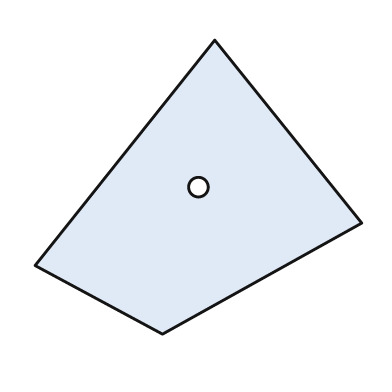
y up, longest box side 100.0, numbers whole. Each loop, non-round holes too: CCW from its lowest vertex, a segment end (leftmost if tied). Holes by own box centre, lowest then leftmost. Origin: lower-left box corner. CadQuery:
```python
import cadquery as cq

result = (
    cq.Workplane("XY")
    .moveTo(39.0, 0.0)
    .lineTo(100.0, 34.0)
    .lineTo(55.0, 90.0)
    .lineTo(0.0, 21.0)
    .close()
    .moveTo(50.0, 45.0)
    .circle(3.0)
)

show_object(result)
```